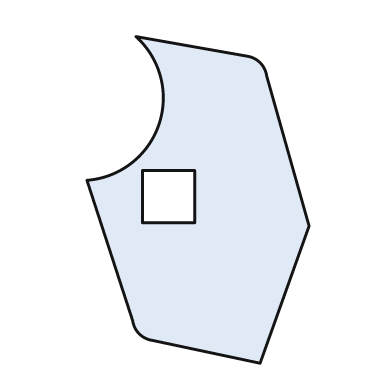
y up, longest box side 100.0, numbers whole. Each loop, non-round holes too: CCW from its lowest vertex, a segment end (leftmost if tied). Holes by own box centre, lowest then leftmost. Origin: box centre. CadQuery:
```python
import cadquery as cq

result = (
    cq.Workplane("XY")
    .moveTo(19.0, -50.0)
    .lineTo(34.0, -8.0)
    .lineTo(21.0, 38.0)
    .threePointArc((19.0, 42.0), (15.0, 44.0))
    .lineTo(-19.0, 50.0)
    .threePointArc((-12.0, 23.0), (-34.0, 6.0))
    .lineTo(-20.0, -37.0)
    .threePointArc((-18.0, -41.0), (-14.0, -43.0))
    .close()
    .moveTo(-17.0, -7.0)
    .lineTo(-1.0, -7.0)
    .lineTo(-1.0, 9.0)
    .lineTo(-17.0, 9.0)
    .close()
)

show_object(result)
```